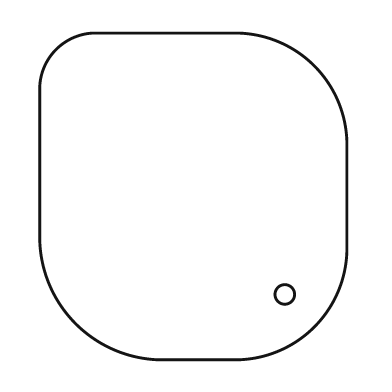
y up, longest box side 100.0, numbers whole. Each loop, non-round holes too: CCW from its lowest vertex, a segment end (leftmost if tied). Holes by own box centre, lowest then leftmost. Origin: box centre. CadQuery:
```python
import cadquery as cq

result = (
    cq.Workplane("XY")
    .moveTo(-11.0, -50.0)
    .lineTo(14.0, -50.0)
    .threePointArc((37.0, -40.0), (47.0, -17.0))
    .lineTo(47.0, 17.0)
    .threePointArc((37.0, 40.0), (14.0, 50.0))
    .lineTo(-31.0, 50.0)
    .threePointArc((-42.0, 45.0), (-47.0, 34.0))
    .lineTo(-47.0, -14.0)
    .threePointArc((-36.0, -39.0), (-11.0, -50.0))
    .close()
    .moveTo(28.0, -30.0)
    .circle(3.0)
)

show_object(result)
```